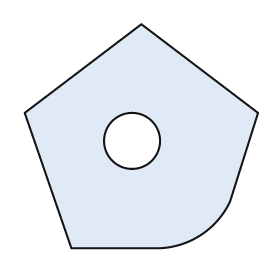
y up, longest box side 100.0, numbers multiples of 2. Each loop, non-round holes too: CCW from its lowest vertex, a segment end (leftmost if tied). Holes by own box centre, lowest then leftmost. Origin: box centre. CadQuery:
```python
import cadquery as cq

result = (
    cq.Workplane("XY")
    .moveTo(-30.0, -48.0)
    .lineTo(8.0, -48.0)
    .threePointArc((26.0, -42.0), (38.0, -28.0))
    .lineTo(50.0, 10.0)
    .lineTo(0.0, 48.0)
    .lineTo(-50.0, 10.0)
    .close()
    .moveTo(-4.0, -2.0)
    .circle(12.0)
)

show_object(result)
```